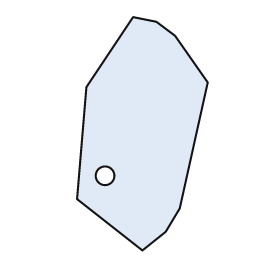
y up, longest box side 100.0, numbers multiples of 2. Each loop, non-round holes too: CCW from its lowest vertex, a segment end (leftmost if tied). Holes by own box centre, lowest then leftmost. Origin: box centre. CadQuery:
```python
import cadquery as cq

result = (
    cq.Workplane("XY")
    .moveTo(0.0, -50.0)
    .lineTo(10.0, -42.0)
    .lineTo(16.0, -32.0)
    .lineTo(28.0, 22.0)
    .lineTo(14.0, 42.0)
    .lineTo(6.0, 48.0)
    .lineTo(-4.0, 50.0)
    .lineTo(-24.0, 20.0)
    .lineTo(-28.0, -28.0)
    .close()
    .moveTo(-16.0, -18.0)
    .circle(4.0)
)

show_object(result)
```